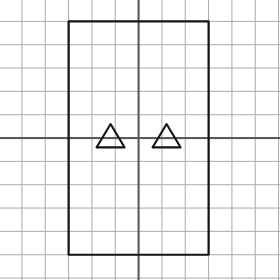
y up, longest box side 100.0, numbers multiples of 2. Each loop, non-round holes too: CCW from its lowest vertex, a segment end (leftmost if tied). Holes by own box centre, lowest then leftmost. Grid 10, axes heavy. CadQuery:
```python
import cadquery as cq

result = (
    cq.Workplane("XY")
    .moveTo(-30.0, -50.0)
    .lineTo(30.0, -50.0)
    .lineTo(30.0, 50.0)
    .lineTo(-30.0, 50.0)
    .close()
    .moveTo(-18.0, -4.0)
    .lineTo(-6.0, -4.0)
    .lineTo(-12.0, 6.0)
    .close()
    .moveTo(6.0, -4.0)
    .lineTo(18.0, -4.0)
    .lineTo(12.0, 6.0)
    .close()
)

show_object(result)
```